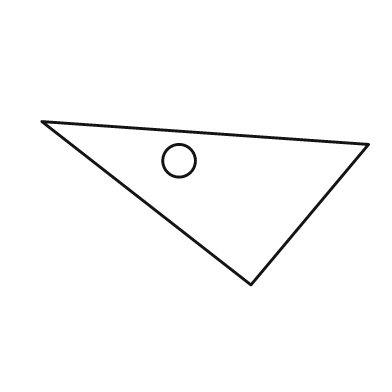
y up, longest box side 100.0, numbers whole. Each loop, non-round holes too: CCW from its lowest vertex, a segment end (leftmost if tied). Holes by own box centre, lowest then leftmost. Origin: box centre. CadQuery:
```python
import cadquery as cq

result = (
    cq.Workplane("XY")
    .moveTo(14.0, -25.0)
    .lineTo(50.0, 18.0)
    .lineTo(-50.0, 25.0)
    .close()
    .moveTo(-8.0, 13.0)
    .circle(5.0)
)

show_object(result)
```